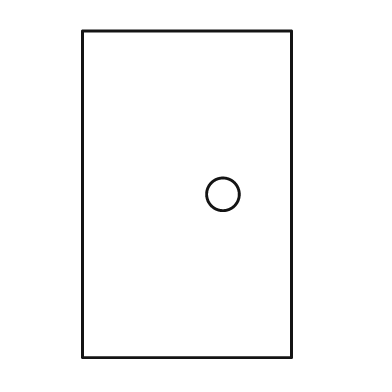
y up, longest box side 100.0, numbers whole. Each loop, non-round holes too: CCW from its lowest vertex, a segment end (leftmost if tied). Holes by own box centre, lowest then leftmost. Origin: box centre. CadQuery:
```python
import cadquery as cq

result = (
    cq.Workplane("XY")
    .moveTo(-32.0, -50.0)
    .lineTo(32.0, -50.0)
    .lineTo(32.0, 50.0)
    .lineTo(-32.0, 50.0)
    .close()
    .moveTo(11.0, 0.0)
    .circle(5.0)
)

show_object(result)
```